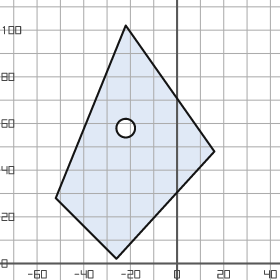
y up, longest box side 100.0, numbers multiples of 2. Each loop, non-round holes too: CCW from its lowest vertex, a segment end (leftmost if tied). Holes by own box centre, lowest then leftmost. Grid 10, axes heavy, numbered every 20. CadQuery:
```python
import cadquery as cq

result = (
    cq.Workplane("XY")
    .moveTo(-26.0, 2.0)
    .lineTo(16.0, 48.0)
    .lineTo(-22.0, 102.0)
    .lineTo(-52.0, 28.0)
    .close()
    .moveTo(-22.0, 58.0)
    .circle(4.0)
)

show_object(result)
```